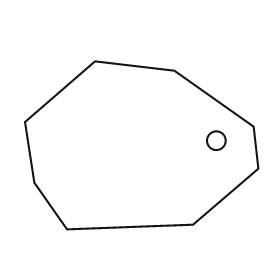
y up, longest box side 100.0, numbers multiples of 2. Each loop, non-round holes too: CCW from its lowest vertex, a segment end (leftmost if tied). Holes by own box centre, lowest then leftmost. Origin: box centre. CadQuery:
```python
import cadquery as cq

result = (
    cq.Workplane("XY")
    .moveTo(-32.0, -36.0)
    .lineTo(22.0, -34.0)
    .lineTo(50.0, -10.0)
    .lineTo(48.0, 8.0)
    .lineTo(14.0, 32.0)
    .lineTo(-20.0, 36.0)
    .lineTo(-50.0, 10.0)
    .lineTo(-46.0, -16.0)
    .close()
    .moveTo(32.0, 2.0)
    .circle(4.0)
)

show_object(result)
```